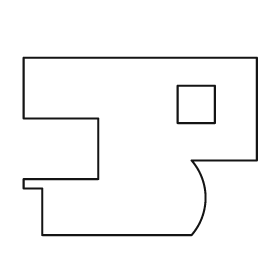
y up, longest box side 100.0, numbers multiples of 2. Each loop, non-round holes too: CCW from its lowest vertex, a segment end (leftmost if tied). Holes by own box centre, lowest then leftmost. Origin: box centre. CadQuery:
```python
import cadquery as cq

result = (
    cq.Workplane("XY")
    .moveTo(-42.0, -38.0)
    .lineTo(22.0, -38.0)
    .threePointArc((28.0, -22.0), (22.0, -6.0))
    .lineTo(50.0, -6.0)
    .lineTo(50.0, 38.0)
    .lineTo(-50.0, 38.0)
    .lineTo(-50.0, 12.0)
    .lineTo(-18.0, 12.0)
    .lineTo(-18.0, -14.0)
    .lineTo(-50.0, -14.0)
    .lineTo(-50.0, -18.0)
    .lineTo(-42.0, -18.0)
    .close()
    .moveTo(16.0, 10.0)
    .lineTo(32.0, 10.0)
    .lineTo(32.0, 26.0)
    .lineTo(16.0, 26.0)
    .close()
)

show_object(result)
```